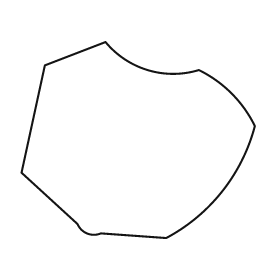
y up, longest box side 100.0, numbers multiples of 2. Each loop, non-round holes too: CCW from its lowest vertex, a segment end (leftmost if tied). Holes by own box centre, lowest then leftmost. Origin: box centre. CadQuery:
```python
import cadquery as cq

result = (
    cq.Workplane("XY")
    .moveTo(12.0, -42.0)
    .threePointArc((36.0, -22.0), (50.0, 6.0))
    .threePointArc((40.0, 20.0), (26.0, 30.0))
    .threePointArc((4.0, 30.0), (-14.0, 42.0))
    .lineTo(-40.0, 32.0)
    .lineTo(-50.0, -14.0)
    .lineTo(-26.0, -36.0)
    .threePointArc((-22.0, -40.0), (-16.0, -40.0))
    .close()
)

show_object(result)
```